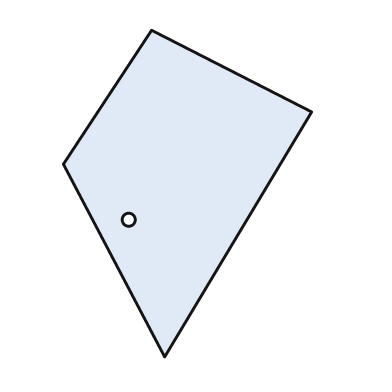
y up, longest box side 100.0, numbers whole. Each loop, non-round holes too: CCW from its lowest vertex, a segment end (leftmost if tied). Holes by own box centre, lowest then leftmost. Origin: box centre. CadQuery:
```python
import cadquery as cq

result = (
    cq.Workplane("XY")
    .moveTo(-7.0, -50.0)
    .lineTo(38.0, 25.0)
    .lineTo(-11.0, 50.0)
    .lineTo(-38.0, 9.0)
    .close()
    .moveTo(-18.0, -8.0)
    .circle(2.0)
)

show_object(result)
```